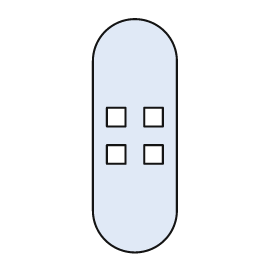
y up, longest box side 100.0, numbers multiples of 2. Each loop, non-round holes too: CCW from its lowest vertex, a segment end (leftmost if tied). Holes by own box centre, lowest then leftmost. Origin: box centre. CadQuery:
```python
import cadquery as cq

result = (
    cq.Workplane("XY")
    .moveTo(-18.0, -32.0)
    .threePointArc((0.0, -50.0), (18.0, -32.0))
    .lineTo(18.0, 32.0)
    .threePointArc((0.0, 50.0), (-18.0, 32.0))
    .close()
    .moveTo(-12.0, -12.0)
    .lineTo(-4.0, -12.0)
    .lineTo(-4.0, -4.0)
    .lineTo(-12.0, -4.0)
    .close()
    .moveTo(4.0, -12.0)
    .lineTo(12.0, -12.0)
    .lineTo(12.0, -4.0)
    .lineTo(4.0, -4.0)
    .close()
    .moveTo(-12.0, 4.0)
    .lineTo(-4.0, 4.0)
    .lineTo(-4.0, 12.0)
    .lineTo(-12.0, 12.0)
    .close()
    .moveTo(4.0, 4.0)
    .lineTo(12.0, 4.0)
    .lineTo(12.0, 12.0)
    .lineTo(4.0, 12.0)
    .close()
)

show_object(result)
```